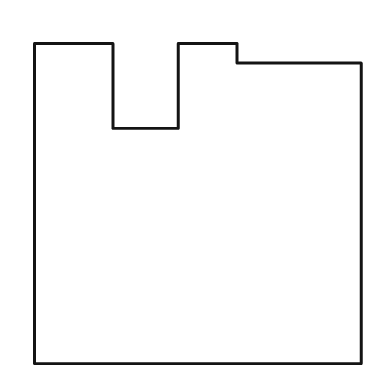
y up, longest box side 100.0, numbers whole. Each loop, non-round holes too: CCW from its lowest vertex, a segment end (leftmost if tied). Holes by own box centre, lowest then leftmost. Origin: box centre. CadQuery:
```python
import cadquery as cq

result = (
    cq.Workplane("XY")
    .moveTo(-50.0, -49.0)
    .lineTo(50.0, -49.0)
    .lineTo(50.0, 43.0)
    .lineTo(12.0, 43.0)
    .lineTo(12.0, 49.0)
    .lineTo(-6.0, 49.0)
    .lineTo(-6.0, 23.0)
    .lineTo(-26.0, 23.0)
    .lineTo(-26.0, 49.0)
    .lineTo(-50.0, 49.0)
    .close()
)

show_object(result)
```